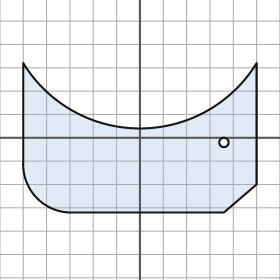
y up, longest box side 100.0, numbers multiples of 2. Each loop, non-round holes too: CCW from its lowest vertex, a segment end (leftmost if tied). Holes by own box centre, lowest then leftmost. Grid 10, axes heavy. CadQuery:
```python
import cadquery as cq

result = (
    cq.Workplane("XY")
    .moveTo(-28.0, -32.0)
    .lineTo(36.0, -32.0)
    .lineTo(50.0, -20.0)
    .lineTo(50.0, 32.0)
    .threePointArc((0.0, 4.0), (-50.0, 32.0))
    .lineTo(-50.0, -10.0)
    .threePointArc((-44.0, -26.0), (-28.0, -32.0))
    .close()
    .moveTo(36.0, -2.0)
    .circle(2.0)
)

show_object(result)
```